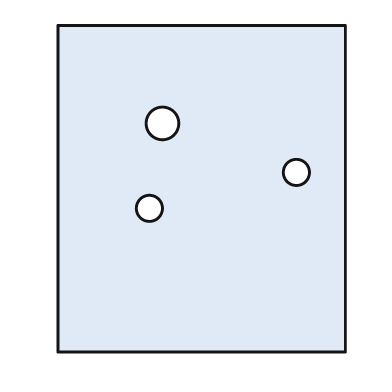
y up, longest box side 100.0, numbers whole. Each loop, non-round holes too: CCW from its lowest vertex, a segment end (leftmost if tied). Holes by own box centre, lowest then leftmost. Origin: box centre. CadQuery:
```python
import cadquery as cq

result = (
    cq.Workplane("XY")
    .moveTo(-44.0, -50.0)
    .lineTo(44.0, -50.0)
    .lineTo(44.0, 50.0)
    .lineTo(-44.0, 50.0)
    .close()
    .moveTo(-16.0, -6.0)
    .circle(4.0)
    .moveTo(29.0, 5.0)
    .circle(4.0)
    .moveTo(-12.0, 20.0)
    .circle(5.0)
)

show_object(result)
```